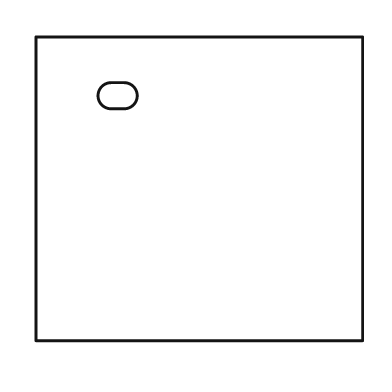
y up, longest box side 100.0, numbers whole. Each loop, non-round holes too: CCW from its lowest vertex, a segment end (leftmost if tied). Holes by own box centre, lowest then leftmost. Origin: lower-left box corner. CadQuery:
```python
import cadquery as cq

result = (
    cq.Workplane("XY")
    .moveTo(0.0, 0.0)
    .lineTo(100.0, 0.0)
    .lineTo(100.0, 93.0)
    .lineTo(0.0, 93.0)
    .close()
    .moveTo(23.0, 71.0)
    .lineTo(27.0, 71.0)
    .threePointArc((31.0, 75.0), (27.0, 79.0))
    .lineTo(23.0, 79.0)
    .threePointArc((19.0, 75.0), (23.0, 71.0))
    .close()
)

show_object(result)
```